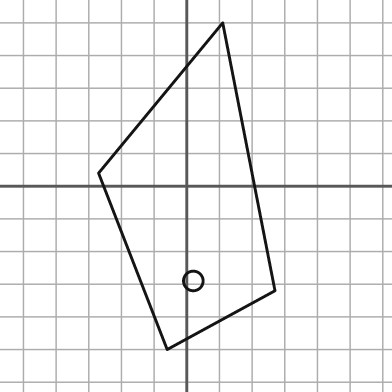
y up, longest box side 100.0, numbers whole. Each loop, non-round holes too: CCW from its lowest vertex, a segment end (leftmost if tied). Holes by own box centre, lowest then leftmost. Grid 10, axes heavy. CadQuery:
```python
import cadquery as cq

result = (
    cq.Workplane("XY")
    .moveTo(-6.0, -50.0)
    .lineTo(27.0, -32.0)
    .lineTo(11.0, 50.0)
    .lineTo(-27.0, 4.0)
    .close()
    .moveTo(2.0, -29.0)
    .circle(3.0)
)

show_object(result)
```